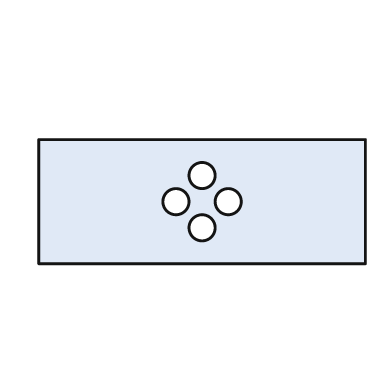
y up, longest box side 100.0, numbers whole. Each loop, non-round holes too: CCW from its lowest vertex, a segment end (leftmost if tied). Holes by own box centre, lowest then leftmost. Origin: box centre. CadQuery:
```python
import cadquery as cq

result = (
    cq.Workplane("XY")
    .moveTo(-50.0, -19.0)
    .lineTo(50.0, -19.0)
    .lineTo(50.0, 19.0)
    .lineTo(-50.0, 19.0)
    .close()
    .moveTo(0.0, -8.0)
    .circle(4.0)
    .moveTo(-8.0, 0.0)
    .circle(4.0)
    .moveTo(8.0, 0.0)
    .circle(4.0)
    .moveTo(0.0, 8.0)
    .circle(4.0)
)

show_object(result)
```